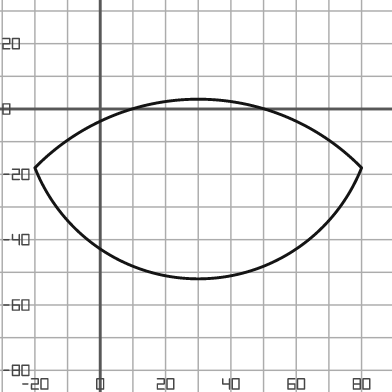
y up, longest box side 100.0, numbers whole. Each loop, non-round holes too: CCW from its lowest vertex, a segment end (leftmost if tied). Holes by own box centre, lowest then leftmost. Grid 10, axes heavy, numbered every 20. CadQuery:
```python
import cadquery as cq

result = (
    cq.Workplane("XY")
    .moveTo(-20.0, -18.0)
    .threePointArc((30.0, -52.0), (80.0, -18.0))
    .threePointArc((30.0, 3.0), (-20.0, -18.0))
    .close()
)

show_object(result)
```